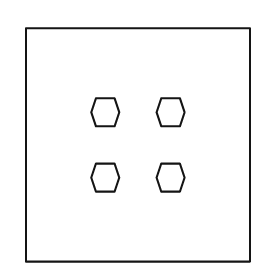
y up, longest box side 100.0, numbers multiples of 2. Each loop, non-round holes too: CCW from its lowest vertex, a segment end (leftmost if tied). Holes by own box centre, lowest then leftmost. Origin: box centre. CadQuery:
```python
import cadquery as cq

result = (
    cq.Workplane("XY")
    .moveTo(-48.0, -50.0)
    .lineTo(48.0, -50.0)
    .lineTo(48.0, 50.0)
    .lineTo(-48.0, 50.0)
    .close()
    .moveTo(-18.0, -20.0)
    .lineTo(-10.0, -20.0)
    .lineTo(-8.0, -14.0)
    .lineTo(-10.0, -8.0)
    .lineTo(-18.0, -8.0)
    .lineTo(-20.0, -14.0)
    .close()
    .moveTo(10.0, -20.0)
    .lineTo(18.0, -20.0)
    .lineTo(20.0, -14.0)
    .lineTo(18.0, -8.0)
    .lineTo(10.0, -8.0)
    .lineTo(8.0, -14.0)
    .close()
    .moveTo(-18.0, 8.0)
    .lineTo(-10.0, 8.0)
    .lineTo(-8.0, 14.0)
    .lineTo(-10.0, 20.0)
    .lineTo(-18.0, 20.0)
    .lineTo(-20.0, 14.0)
    .close()
    .moveTo(10.0, 8.0)
    .lineTo(18.0, 8.0)
    .lineTo(20.0, 14.0)
    .lineTo(18.0, 20.0)
    .lineTo(10.0, 20.0)
    .lineTo(8.0, 14.0)
    .close()
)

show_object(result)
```